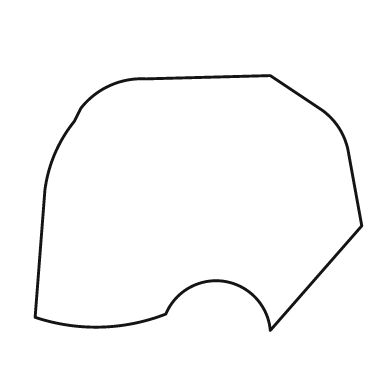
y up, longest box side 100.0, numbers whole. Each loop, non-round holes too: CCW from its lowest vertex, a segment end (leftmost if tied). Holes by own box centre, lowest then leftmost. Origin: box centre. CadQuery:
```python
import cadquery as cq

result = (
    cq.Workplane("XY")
    .moveTo(22.0, -39.0)
    .lineTo(50.0, -7.0)
    .lineTo(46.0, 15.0)
    .threePointArc((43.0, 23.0), (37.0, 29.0))
    .lineTo(22.0, 39.0)
    .lineTo(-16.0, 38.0)
    .threePointArc((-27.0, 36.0), (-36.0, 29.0))
    .lineTo(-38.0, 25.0)
    .threePointArc((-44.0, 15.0), (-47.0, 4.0))
    .lineTo(-50.0, -35.0)
    .threePointArc((-30.0, -38.0), (-10.0, -34.0))
    .threePointArc((8.0, -24.0), (22.0, -39.0))
    .close()
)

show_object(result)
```